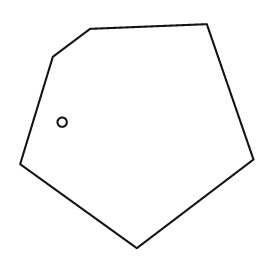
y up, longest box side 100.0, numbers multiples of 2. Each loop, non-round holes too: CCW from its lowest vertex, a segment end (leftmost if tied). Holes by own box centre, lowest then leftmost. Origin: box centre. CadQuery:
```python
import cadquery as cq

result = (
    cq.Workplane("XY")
    .moveTo(0.0, -48.0)
    .lineTo(50.0, -10.0)
    .lineTo(30.0, 48.0)
    .lineTo(-20.0, 46.0)
    .lineTo(-36.0, 34.0)
    .lineTo(-50.0, -12.0)
    .close()
    .moveTo(-32.0, 6.0)
    .circle(2.0)
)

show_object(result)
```